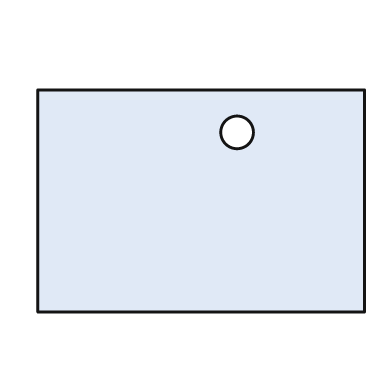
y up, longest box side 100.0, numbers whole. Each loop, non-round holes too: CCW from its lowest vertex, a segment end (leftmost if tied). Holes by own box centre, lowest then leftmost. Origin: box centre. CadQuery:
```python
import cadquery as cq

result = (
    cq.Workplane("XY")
    .moveTo(-50.0, -34.0)
    .lineTo(50.0, -34.0)
    .lineTo(50.0, 34.0)
    .lineTo(-50.0, 34.0)
    .close()
    .moveTo(11.0, 21.0)
    .circle(5.0)
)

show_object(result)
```